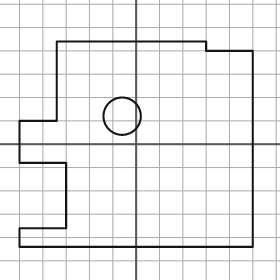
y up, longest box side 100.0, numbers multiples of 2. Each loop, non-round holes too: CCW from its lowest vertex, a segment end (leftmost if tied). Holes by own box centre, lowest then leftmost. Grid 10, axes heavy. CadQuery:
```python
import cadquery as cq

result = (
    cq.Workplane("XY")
    .moveTo(-50.0, -44.0)
    .lineTo(50.0, -44.0)
    .lineTo(50.0, 40.0)
    .lineTo(30.0, 40.0)
    .lineTo(30.0, 44.0)
    .lineTo(-34.0, 44.0)
    .lineTo(-34.0, 10.0)
    .lineTo(-50.0, 10.0)
    .lineTo(-50.0, -8.0)
    .lineTo(-30.0, -8.0)
    .lineTo(-30.0, -36.0)
    .lineTo(-50.0, -36.0)
    .close()
    .moveTo(-6.0, 12.0)
    .circle(8.0)
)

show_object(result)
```